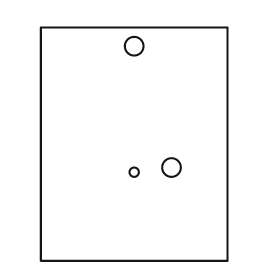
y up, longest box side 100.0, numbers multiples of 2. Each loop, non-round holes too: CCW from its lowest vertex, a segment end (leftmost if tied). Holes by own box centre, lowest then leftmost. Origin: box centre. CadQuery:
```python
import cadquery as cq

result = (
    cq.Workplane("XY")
    .moveTo(-40.0, -50.0)
    .lineTo(40.0, -50.0)
    .lineTo(40.0, 50.0)
    .lineTo(-40.0, 50.0)
    .close()
    .moveTo(0.0, -12.0)
    .circle(2.0)
    .moveTo(16.0, -10.0)
    .circle(4.0)
    .moveTo(0.0, 42.0)
    .circle(4.0)
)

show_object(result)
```